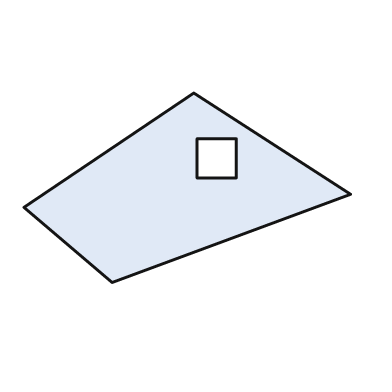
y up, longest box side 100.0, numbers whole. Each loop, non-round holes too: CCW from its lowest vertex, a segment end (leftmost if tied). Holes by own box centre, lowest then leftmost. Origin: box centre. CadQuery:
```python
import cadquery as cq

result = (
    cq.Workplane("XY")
    .moveTo(-23.0, -29.0)
    .lineTo(50.0, -2.0)
    .lineTo(2.0, 29.0)
    .lineTo(-50.0, -6.0)
    .close()
    .moveTo(3.0, 3.0)
    .lineTo(15.0, 3.0)
    .lineTo(15.0, 15.0)
    .lineTo(3.0, 15.0)
    .close()
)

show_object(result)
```